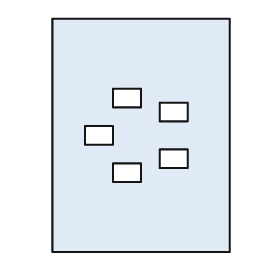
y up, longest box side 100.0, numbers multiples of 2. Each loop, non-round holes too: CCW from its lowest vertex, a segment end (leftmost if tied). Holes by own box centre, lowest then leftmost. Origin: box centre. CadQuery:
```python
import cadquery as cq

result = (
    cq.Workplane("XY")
    .moveTo(-38.0, -50.0)
    .lineTo(38.0, -50.0)
    .lineTo(38.0, 50.0)
    .lineTo(-38.0, 50.0)
    .close()
    .moveTo(-12.0, -20.0)
    .lineTo(0.0, -20.0)
    .lineTo(0.0, -12.0)
    .lineTo(-12.0, -12.0)
    .close()
    .moveTo(8.0, -14.0)
    .lineTo(20.0, -14.0)
    .lineTo(20.0, -6.0)
    .lineTo(8.0, -6.0)
    .close()
    .moveTo(-24.0, -4.0)
    .lineTo(-12.0, -4.0)
    .lineTo(-12.0, 4.0)
    .lineTo(-24.0, 4.0)
    .close()
    .moveTo(8.0, 6.0)
    .lineTo(20.0, 6.0)
    .lineTo(20.0, 14.0)
    .lineTo(8.0, 14.0)
    .close()
    .moveTo(-12.0, 12.0)
    .lineTo(0.0, 12.0)
    .lineTo(0.0, 20.0)
    .lineTo(-12.0, 20.0)
    .close()
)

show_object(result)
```